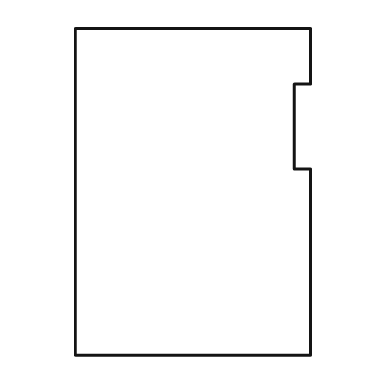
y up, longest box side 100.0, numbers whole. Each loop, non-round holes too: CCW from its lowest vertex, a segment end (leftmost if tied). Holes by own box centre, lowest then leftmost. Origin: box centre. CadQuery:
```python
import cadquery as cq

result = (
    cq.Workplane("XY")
    .moveTo(-36.0, -50.0)
    .lineTo(36.0, -50.0)
    .lineTo(36.0, 7.0)
    .lineTo(31.0, 7.0)
    .lineTo(31.0, 33.0)
    .lineTo(36.0, 33.0)
    .lineTo(36.0, 50.0)
    .lineTo(-36.0, 50.0)
    .close()
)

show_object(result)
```